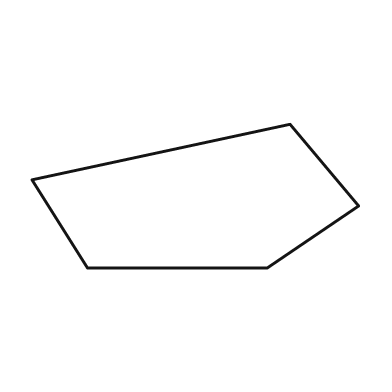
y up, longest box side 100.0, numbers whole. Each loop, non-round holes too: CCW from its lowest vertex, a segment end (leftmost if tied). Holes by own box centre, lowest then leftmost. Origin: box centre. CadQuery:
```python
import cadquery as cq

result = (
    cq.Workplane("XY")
    .moveTo(-33.0, -22.0)
    .lineTo(22.0, -22.0)
    .lineTo(50.0, -3.0)
    .lineTo(29.0, 22.0)
    .lineTo(-50.0, 5.0)
    .close()
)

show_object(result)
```